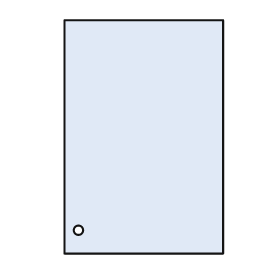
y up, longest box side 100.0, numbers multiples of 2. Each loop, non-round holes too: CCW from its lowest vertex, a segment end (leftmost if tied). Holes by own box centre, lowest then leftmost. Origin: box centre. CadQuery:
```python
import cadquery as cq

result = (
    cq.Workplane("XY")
    .moveTo(-34.0, -50.0)
    .lineTo(34.0, -50.0)
    .lineTo(34.0, 50.0)
    .lineTo(-34.0, 50.0)
    .close()
    .moveTo(-28.0, -40.0)
    .circle(2.0)
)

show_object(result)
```